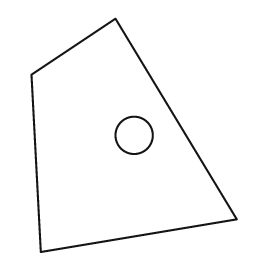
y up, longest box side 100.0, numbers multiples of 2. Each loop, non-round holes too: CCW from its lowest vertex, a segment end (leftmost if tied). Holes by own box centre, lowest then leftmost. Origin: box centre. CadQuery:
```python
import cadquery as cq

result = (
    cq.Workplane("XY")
    .moveTo(-40.0, -50.0)
    .lineTo(44.0, -36.0)
    .lineTo(-8.0, 50.0)
    .lineTo(-44.0, 26.0)
    .close()
    .moveTo(0.0, 0.0)
    .circle(8.0)
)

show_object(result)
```